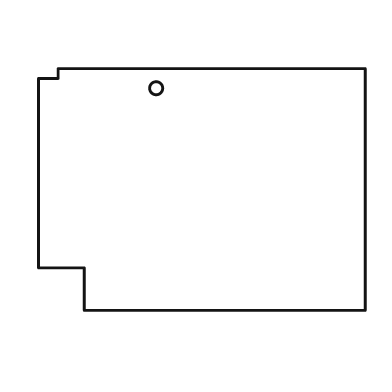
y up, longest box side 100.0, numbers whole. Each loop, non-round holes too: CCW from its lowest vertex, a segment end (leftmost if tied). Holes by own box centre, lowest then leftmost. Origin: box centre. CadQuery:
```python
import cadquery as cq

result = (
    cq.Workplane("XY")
    .moveTo(-36.0, -37.0)
    .lineTo(50.0, -37.0)
    .lineTo(50.0, 37.0)
    .lineTo(-44.0, 37.0)
    .lineTo(-44.0, 34.0)
    .lineTo(-50.0, 34.0)
    .lineTo(-50.0, -24.0)
    .lineTo(-36.0, -24.0)
    .close()
    .moveTo(-14.0, 31.0)
    .circle(2.0)
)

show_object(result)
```